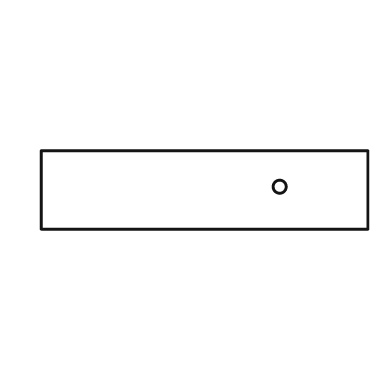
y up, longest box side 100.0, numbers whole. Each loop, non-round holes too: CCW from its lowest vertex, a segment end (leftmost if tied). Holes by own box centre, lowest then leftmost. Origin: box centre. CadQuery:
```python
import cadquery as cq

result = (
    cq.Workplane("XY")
    .moveTo(-50.0, -12.0)
    .lineTo(50.0, -12.0)
    .lineTo(50.0, 12.0)
    .lineTo(-50.0, 12.0)
    .close()
    .moveTo(23.0, 1.0)
    .circle(2.0)
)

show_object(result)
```